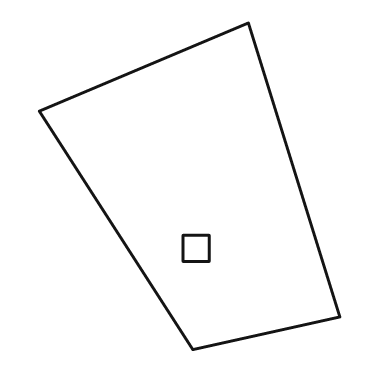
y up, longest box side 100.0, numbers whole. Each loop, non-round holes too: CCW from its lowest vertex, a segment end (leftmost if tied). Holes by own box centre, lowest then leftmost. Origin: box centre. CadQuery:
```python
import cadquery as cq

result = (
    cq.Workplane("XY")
    .moveTo(1.0, -50.0)
    .lineTo(46.0, -40.0)
    .lineTo(18.0, 50.0)
    .lineTo(-46.0, 23.0)
    .close()
    .moveTo(-2.0, -23.0)
    .lineTo(6.0, -23.0)
    .lineTo(6.0, -15.0)
    .lineTo(-2.0, -15.0)
    .close()
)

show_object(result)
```